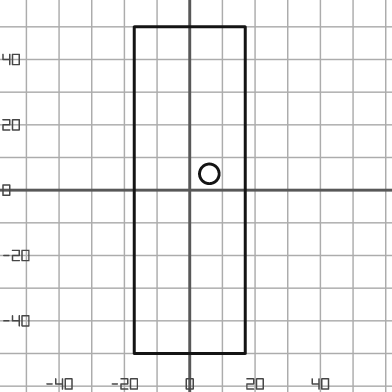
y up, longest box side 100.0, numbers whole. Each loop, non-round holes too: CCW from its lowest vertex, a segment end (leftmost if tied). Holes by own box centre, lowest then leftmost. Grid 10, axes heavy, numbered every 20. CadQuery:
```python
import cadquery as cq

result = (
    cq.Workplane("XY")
    .moveTo(-17.0, -50.0)
    .lineTo(17.0, -50.0)
    .lineTo(17.0, 50.0)
    .lineTo(-17.0, 50.0)
    .close()
    .moveTo(6.0, 5.0)
    .circle(3.0)
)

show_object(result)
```